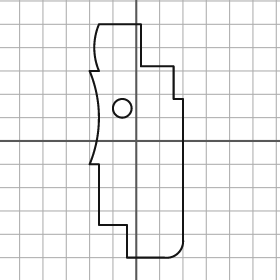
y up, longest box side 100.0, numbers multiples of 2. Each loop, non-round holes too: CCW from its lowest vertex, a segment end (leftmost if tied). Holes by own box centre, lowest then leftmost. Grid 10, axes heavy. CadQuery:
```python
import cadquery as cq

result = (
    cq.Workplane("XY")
    .moveTo(-4.0, -50.0)
    .lineTo(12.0, -50.0)
    .threePointArc((18.0, -48.0), (20.0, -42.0))
    .lineTo(20.0, 18.0)
    .lineTo(16.0, 18.0)
    .lineTo(16.0, 32.0)
    .lineTo(2.0, 32.0)
    .lineTo(2.0, 50.0)
    .lineTo(-16.0, 50.0)
    .threePointArc((-18.0, 40.0), (-16.0, 30.0))
    .lineTo(-20.0, 30.0)
    .threePointArc((-16.0, 10.0), (-20.0, -10.0))
    .lineTo(-16.0, -10.0)
    .lineTo(-16.0, -36.0)
    .lineTo(-4.0, -36.0)
    .close()
    .moveTo(-6.0, 14.0)
    .circle(4.0)
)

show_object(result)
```